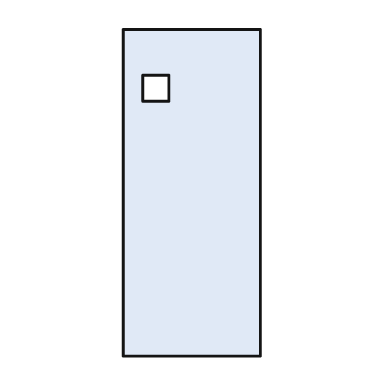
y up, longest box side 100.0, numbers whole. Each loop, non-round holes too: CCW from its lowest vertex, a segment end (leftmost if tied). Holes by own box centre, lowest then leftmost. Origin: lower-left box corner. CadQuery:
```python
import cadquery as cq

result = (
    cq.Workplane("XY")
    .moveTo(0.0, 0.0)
    .lineTo(42.0, 0.0)
    .lineTo(42.0, 100.0)
    .lineTo(0.0, 100.0)
    .close()
    .moveTo(6.0, 78.0)
    .lineTo(14.0, 78.0)
    .lineTo(14.0, 86.0)
    .lineTo(6.0, 86.0)
    .close()
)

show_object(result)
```